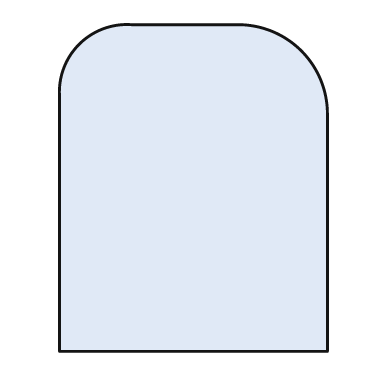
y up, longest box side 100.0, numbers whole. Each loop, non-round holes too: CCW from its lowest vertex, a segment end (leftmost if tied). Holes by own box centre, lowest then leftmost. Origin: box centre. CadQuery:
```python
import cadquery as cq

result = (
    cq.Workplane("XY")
    .moveTo(-41.0, -50.0)
    .lineTo(41.0, -50.0)
    .lineTo(41.0, 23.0)
    .threePointArc((33.0, 42.0), (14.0, 50.0))
    .lineTo(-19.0, 50.0)
    .threePointArc((-35.0, 44.0), (-41.0, 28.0))
    .close()
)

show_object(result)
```